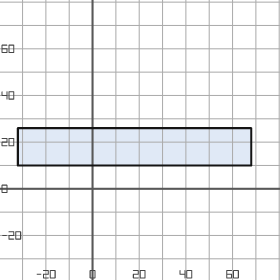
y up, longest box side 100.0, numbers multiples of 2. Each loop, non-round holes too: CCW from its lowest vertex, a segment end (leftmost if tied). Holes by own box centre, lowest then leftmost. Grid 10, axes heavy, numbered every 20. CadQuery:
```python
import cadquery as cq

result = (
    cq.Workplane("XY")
    .moveTo(-32.0, 10.0)
    .lineTo(68.0, 10.0)
    .lineTo(68.0, 26.0)
    .lineTo(-32.0, 26.0)
    .close()
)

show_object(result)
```